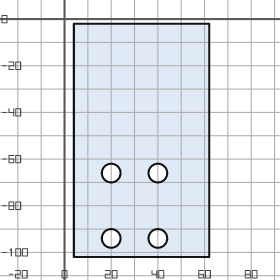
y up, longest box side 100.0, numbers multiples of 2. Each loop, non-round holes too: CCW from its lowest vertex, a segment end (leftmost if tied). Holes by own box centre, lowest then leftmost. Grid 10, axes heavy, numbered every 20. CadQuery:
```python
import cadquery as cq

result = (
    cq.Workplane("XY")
    .moveTo(4.0, -102.0)
    .lineTo(62.0, -102.0)
    .lineTo(62.0, -2.0)
    .lineTo(4.0, -2.0)
    .close()
    .moveTo(20.0, -94.0)
    .circle(4.0)
    .moveTo(40.0, -94.0)
    .circle(4.0)
    .moveTo(20.0, -66.0)
    .circle(4.0)
    .moveTo(40.0, -66.0)
    .circle(4.0)
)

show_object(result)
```